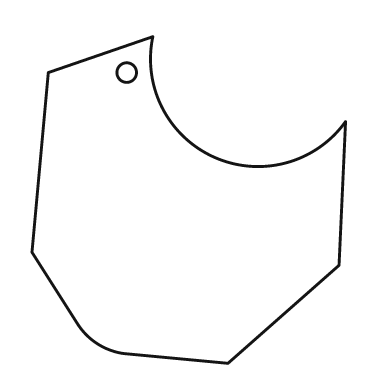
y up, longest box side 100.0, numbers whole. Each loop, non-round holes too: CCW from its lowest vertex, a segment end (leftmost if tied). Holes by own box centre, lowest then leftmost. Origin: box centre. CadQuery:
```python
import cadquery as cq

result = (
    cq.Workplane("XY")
    .moveTo(12.0, -50.0)
    .lineTo(46.0, -20.0)
    .lineTo(48.0, 24.0)
    .threePointArc((8.0, 13.0), (-11.0, 50.0))
    .lineTo(-43.0, 39.0)
    .lineTo(-48.0, -16.0)
    .lineTo(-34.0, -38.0)
    .threePointArc((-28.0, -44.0), (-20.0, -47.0))
    .close()
    .moveTo(-19.0, 39.0)
    .circle(3.0)
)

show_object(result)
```